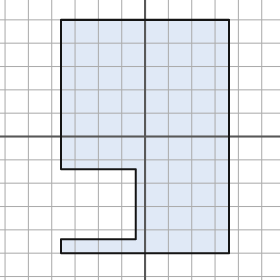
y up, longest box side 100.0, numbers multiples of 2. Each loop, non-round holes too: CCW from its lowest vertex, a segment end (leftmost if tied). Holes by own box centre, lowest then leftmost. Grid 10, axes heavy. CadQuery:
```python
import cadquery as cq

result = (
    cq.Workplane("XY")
    .moveTo(-36.0, -50.0)
    .lineTo(36.0, -50.0)
    .lineTo(36.0, 50.0)
    .lineTo(-36.0, 50.0)
    .lineTo(-36.0, -14.0)
    .lineTo(-4.0, -14.0)
    .lineTo(-4.0, -44.0)
    .lineTo(-36.0, -44.0)
    .close()
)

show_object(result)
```